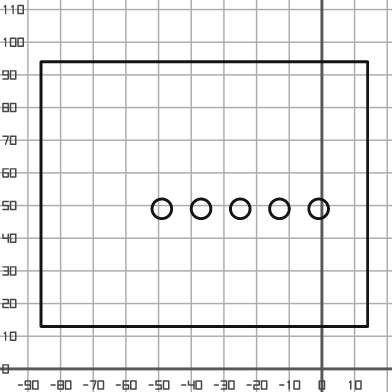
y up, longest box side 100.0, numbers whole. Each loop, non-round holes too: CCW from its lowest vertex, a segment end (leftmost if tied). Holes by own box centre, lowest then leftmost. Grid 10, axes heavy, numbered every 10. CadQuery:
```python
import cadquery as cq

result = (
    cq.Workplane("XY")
    .moveTo(-86.0, 13.0)
    .lineTo(14.0, 13.0)
    .lineTo(14.0, 94.0)
    .lineTo(-86.0, 94.0)
    .close()
    .moveTo(-49.0, 49.0)
    .circle(3.0)
    .moveTo(-37.0, 49.0)
    .circle(3.0)
    .moveTo(-25.0, 49.0)
    .circle(3.0)
    .moveTo(-13.0, 49.0)
    .circle(3.0)
    .moveTo(-1.0, 49.0)
    .circle(3.0)
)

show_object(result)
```